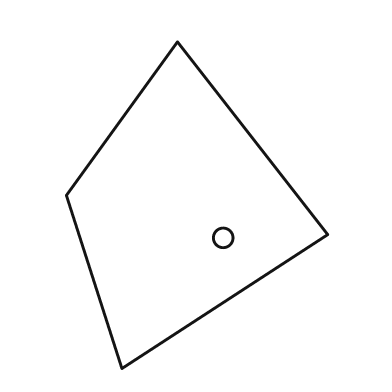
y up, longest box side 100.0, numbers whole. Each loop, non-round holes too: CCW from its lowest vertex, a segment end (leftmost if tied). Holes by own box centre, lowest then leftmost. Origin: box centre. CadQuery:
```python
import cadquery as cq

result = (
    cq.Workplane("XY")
    .moveTo(-23.0, -50.0)
    .lineTo(40.0, -9.0)
    .lineTo(-6.0, 50.0)
    .lineTo(-40.0, 3.0)
    .close()
    .moveTo(8.0, -10.0)
    .circle(3.0)
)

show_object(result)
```